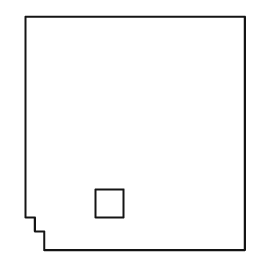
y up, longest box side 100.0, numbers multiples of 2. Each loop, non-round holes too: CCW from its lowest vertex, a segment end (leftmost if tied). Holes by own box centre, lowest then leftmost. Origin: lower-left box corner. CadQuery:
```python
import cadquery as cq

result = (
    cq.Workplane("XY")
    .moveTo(8.0, 0.0)
    .lineTo(94.0, 0.0)
    .lineTo(94.0, 100.0)
    .lineTo(0.0, 100.0)
    .lineTo(0.0, 14.0)
    .lineTo(4.0, 14.0)
    .lineTo(4.0, 8.0)
    .lineTo(8.0, 8.0)
    .close()
    .moveTo(30.0, 14.0)
    .lineTo(42.0, 14.0)
    .lineTo(42.0, 26.0)
    .lineTo(30.0, 26.0)
    .close()
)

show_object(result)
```